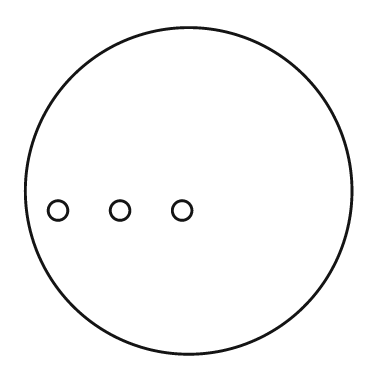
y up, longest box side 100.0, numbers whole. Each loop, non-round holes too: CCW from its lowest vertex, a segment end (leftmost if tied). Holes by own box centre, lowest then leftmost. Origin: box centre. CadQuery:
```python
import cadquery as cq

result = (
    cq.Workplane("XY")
    .moveTo(0.0, 0.0)
    .circle(50.0)
    .moveTo(-40.0, -6.0)
    .circle(3.0)
    .moveTo(-21.0, -6.0)
    .circle(3.0)
    .moveTo(-2.0, -6.0)
    .circle(3.0)
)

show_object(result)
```